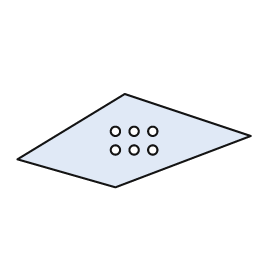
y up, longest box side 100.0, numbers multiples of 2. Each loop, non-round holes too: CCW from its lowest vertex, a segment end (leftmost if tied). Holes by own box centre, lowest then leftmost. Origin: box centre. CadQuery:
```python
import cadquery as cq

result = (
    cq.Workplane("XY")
    .moveTo(-8.0, -20.0)
    .lineTo(50.0, 2.0)
    .lineTo(-4.0, 20.0)
    .lineTo(-50.0, -8.0)
    .close()
    .moveTo(-8.0, -4.0)
    .circle(2.0)
    .moveTo(0.0, -4.0)
    .circle(2.0)
    .moveTo(8.0, -4.0)
    .circle(2.0)
    .moveTo(-8.0, 4.0)
    .circle(2.0)
    .moveTo(0.0, 4.0)
    .circle(2.0)
    .moveTo(8.0, 4.0)
    .circle(2.0)
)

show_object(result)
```